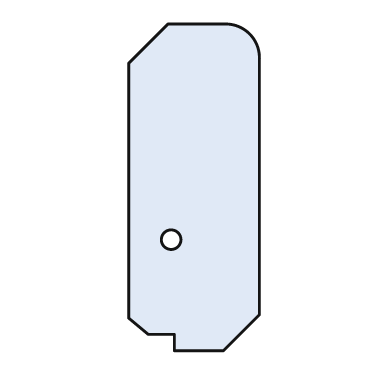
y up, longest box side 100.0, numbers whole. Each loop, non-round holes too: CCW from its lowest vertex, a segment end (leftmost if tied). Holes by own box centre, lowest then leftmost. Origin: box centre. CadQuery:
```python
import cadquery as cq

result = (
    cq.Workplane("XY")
    .moveTo(-6.0, -50.0)
    .lineTo(9.0, -50.0)
    .lineTo(20.0, -39.0)
    .lineTo(20.0, 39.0)
    .threePointArc((17.0, 47.0), (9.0, 50.0))
    .lineTo(-8.0, 50.0)
    .lineTo(-20.0, 38.0)
    .lineTo(-20.0, -40.0)
    .lineTo(-14.0, -45.0)
    .lineTo(-6.0, -45.0)
    .close()
    .moveTo(-7.0, -16.0)
    .circle(3.0)
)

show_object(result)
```